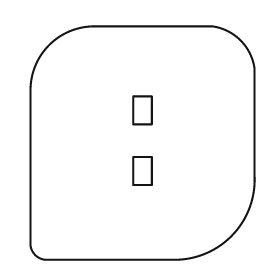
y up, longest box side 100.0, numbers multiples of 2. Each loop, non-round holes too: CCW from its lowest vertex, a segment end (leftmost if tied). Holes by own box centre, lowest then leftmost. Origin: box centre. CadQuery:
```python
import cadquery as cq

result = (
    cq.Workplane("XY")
    .moveTo(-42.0, -50.0)
    .lineTo(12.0, -50.0)
    .threePointArc((38.0, -40.0), (48.0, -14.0))
    .lineTo(48.0, 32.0)
    .threePointArc((42.0, 44.0), (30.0, 50.0))
    .lineTo(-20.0, 50.0)
    .threePointArc((-40.0, 42.0), (-48.0, 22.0))
    .lineTo(-48.0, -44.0)
    .threePointArc((-46.0, -48.0), (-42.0, -50.0))
    .close()
    .moveTo(-4.0, -18.0)
    .lineTo(4.0, -18.0)
    .lineTo(4.0, -6.0)
    .lineTo(-4.0, -6.0)
    .close()
    .moveTo(-4.0, 8.0)
    .lineTo(4.0, 8.0)
    .lineTo(4.0, 20.0)
    .lineTo(-4.0, 20.0)
    .close()
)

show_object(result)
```